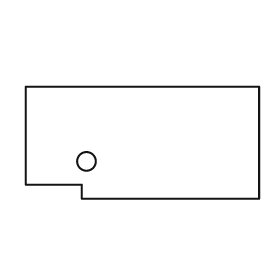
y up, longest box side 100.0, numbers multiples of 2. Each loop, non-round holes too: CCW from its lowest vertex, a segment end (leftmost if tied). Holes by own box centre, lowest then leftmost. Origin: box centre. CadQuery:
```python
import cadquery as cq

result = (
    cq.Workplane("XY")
    .moveTo(-26.0, -24.0)
    .lineTo(50.0, -24.0)
    .lineTo(50.0, 24.0)
    .lineTo(-50.0, 24.0)
    .lineTo(-50.0, -18.0)
    .lineTo(-26.0, -18.0)
    .close()
    .moveTo(-24.0, -8.0)
    .circle(4.0)
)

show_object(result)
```